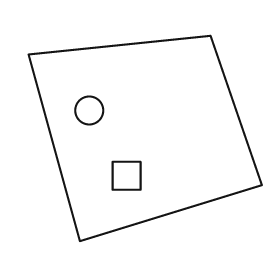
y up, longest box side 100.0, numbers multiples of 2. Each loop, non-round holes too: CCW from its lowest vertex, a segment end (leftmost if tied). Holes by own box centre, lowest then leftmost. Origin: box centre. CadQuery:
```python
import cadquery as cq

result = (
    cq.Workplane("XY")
    .moveTo(-28.0, -44.0)
    .lineTo(50.0, -20.0)
    .lineTo(28.0, 44.0)
    .lineTo(-50.0, 36.0)
    .close()
    .moveTo(-14.0, -22.0)
    .lineTo(-2.0, -22.0)
    .lineTo(-2.0, -10.0)
    .lineTo(-14.0, -10.0)
    .close()
    .moveTo(-24.0, 12.0)
    .circle(6.0)
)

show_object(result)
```